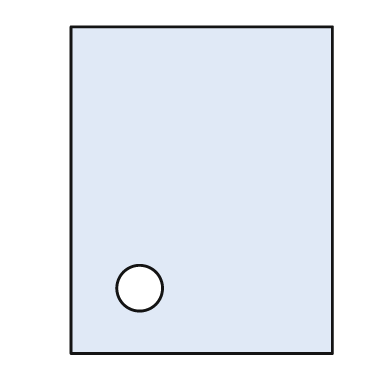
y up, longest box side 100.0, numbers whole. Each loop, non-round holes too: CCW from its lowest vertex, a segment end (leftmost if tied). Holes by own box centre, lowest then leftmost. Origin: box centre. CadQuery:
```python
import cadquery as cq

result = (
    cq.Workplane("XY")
    .moveTo(-40.0, -50.0)
    .lineTo(40.0, -50.0)
    .lineTo(40.0, 50.0)
    .lineTo(-40.0, 50.0)
    .close()
    .moveTo(-19.0, -30.0)
    .circle(7.0)
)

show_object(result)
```